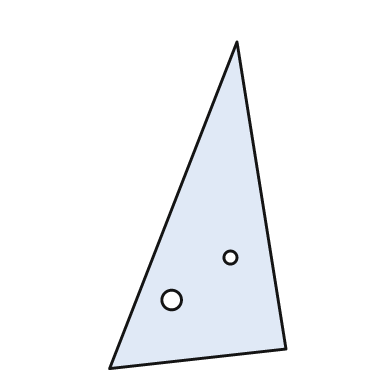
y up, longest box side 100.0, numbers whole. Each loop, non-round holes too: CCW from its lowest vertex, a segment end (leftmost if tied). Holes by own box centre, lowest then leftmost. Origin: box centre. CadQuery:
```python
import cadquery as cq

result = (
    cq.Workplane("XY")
    .moveTo(-27.0, -50.0)
    .lineTo(27.0, -44.0)
    .lineTo(12.0, 50.0)
    .close()
    .moveTo(-8.0, -29.0)
    .circle(3.0)
    .moveTo(10.0, -16.0)
    .circle(2.0)
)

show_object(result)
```